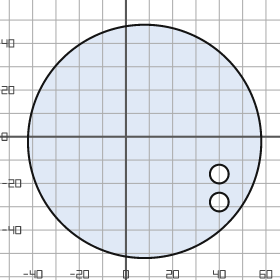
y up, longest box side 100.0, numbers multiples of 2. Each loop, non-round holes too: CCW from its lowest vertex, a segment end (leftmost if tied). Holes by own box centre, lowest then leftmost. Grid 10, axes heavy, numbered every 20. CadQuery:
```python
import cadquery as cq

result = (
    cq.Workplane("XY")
    .moveTo(8.0, -2.0)
    .circle(50.0)
    .moveTo(40.0, -28.0)
    .circle(4.0)
    .moveTo(40.0, -16.0)
    .circle(4.0)
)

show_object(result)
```